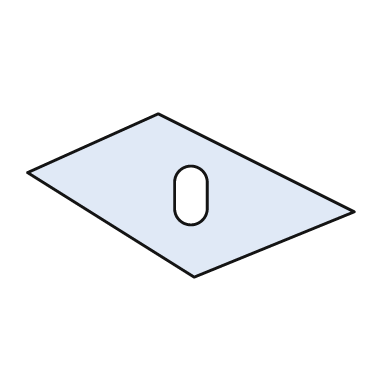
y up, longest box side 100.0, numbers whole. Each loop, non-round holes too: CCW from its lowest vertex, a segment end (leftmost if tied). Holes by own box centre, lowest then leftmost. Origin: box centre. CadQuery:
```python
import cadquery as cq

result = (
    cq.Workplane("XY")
    .moveTo(1.0, -25.0)
    .lineTo(50.0, -5.0)
    .lineTo(-10.0, 25.0)
    .lineTo(-50.0, 7.0)
    .close()
    .moveTo(-5.0, -4.0)
    .threePointArc((0.0, -9.0), (5.0, -4.0))
    .lineTo(5.0, 4.0)
    .threePointArc((0.0, 9.0), (-5.0, 4.0))
    .close()
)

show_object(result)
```